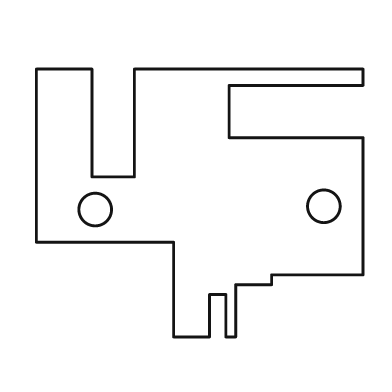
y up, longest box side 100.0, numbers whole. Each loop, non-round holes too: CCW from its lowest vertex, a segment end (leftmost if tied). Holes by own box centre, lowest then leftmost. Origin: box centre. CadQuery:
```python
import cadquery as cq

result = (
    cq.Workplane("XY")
    .moveTo(-8.0, -41.0)
    .lineTo(3.0, -41.0)
    .lineTo(3.0, -28.0)
    .lineTo(8.0, -28.0)
    .lineTo(8.0, -41.0)
    .lineTo(11.0, -41.0)
    .lineTo(11.0, -25.0)
    .lineTo(22.0, -25.0)
    .lineTo(22.0, -22.0)
    .lineTo(50.0, -22.0)
    .lineTo(50.0, 20.0)
    .lineTo(9.0, 20.0)
    .lineTo(9.0, 36.0)
    .lineTo(50.0, 36.0)
    .lineTo(50.0, 41.0)
    .lineTo(-20.0, 41.0)
    .lineTo(-20.0, 8.0)
    .lineTo(-33.0, 8.0)
    .lineTo(-33.0, 41.0)
    .lineTo(-50.0, 41.0)
    .lineTo(-50.0, -12.0)
    .lineTo(-8.0, -12.0)
    .close()
    .moveTo(-32.0, -2.0)
    .circle(5.0)
    .moveTo(38.0, -1.0)
    .circle(5.0)
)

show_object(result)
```